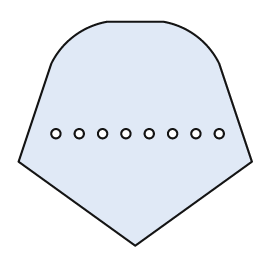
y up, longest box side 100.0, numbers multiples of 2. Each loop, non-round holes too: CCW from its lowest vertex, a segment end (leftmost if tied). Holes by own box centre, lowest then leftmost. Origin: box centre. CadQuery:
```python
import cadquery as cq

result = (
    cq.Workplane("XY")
    .moveTo(0.0, -48.0)
    .lineTo(50.0, -12.0)
    .lineTo(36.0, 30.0)
    .threePointArc((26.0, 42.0), (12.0, 48.0))
    .lineTo(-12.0, 48.0)
    .threePointArc((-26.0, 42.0), (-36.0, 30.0))
    .lineTo(-50.0, -12.0)
    .close()
    .moveTo(-34.0, 0.0)
    .circle(2.0)
    .moveTo(-24.0, 0.0)
    .circle(2.0)
    .moveTo(-14.0, 0.0)
    .circle(2.0)
    .moveTo(-4.0, 0.0)
    .circle(2.0)
    .moveTo(6.0, 0.0)
    .circle(2.0)
    .moveTo(16.0, 0.0)
    .circle(2.0)
    .moveTo(26.0, 0.0)
    .circle(2.0)
    .moveTo(36.0, 0.0)
    .circle(2.0)
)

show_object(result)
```